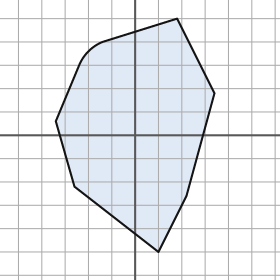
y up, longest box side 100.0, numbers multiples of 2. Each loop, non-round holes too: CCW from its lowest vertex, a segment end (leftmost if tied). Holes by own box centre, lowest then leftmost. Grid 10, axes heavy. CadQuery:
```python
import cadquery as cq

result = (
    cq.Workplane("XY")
    .moveTo(10.0, -50.0)
    .lineTo(22.0, -26.0)
    .lineTo(34.0, 18.0)
    .lineTo(18.0, 50.0)
    .lineTo(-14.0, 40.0)
    .threePointArc((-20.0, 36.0), (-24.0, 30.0))
    .lineTo(-34.0, 6.0)
    .lineTo(-26.0, -22.0)
    .close()
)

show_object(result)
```